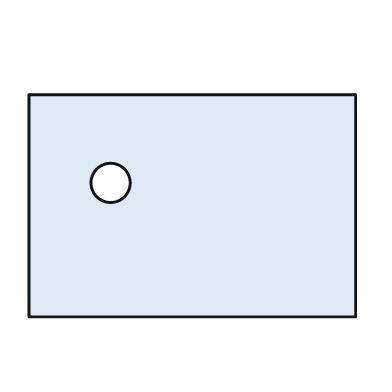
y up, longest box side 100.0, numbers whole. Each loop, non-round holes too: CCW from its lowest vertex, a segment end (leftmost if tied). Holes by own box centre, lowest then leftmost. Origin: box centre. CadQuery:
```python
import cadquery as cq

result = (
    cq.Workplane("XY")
    .moveTo(-50.0, -34.0)
    .lineTo(50.0, -34.0)
    .lineTo(50.0, 34.0)
    .lineTo(-50.0, 34.0)
    .close()
    .moveTo(-25.0, 7.0)
    .circle(6.0)
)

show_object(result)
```